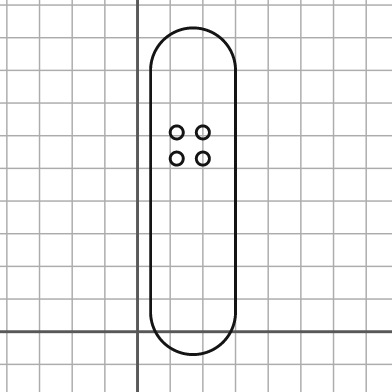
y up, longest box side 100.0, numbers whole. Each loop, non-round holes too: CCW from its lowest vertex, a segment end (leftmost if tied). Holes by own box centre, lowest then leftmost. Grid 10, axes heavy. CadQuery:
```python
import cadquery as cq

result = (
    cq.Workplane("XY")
    .moveTo(4.0, 6.0)
    .threePointArc((17.0, -7.0), (30.0, 6.0))
    .lineTo(30.0, 80.0)
    .threePointArc((17.0, 93.0), (4.0, 80.0))
    .close()
    .moveTo(12.0, 53.0)
    .circle(2.0)
    .moveTo(20.0, 53.0)
    .circle(2.0)
    .moveTo(12.0, 61.0)
    .circle(2.0)
    .moveTo(20.0, 61.0)
    .circle(2.0)
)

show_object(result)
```